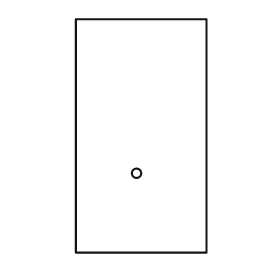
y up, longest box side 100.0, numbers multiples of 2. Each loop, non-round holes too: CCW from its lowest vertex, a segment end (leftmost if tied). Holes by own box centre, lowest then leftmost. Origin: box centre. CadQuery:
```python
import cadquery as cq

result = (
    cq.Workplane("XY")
    .moveTo(-28.0, -50.0)
    .lineTo(28.0, -50.0)
    .lineTo(28.0, 50.0)
    .lineTo(-28.0, 50.0)
    .close()
    .moveTo(-2.0, -16.0)
    .circle(2.0)
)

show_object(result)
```